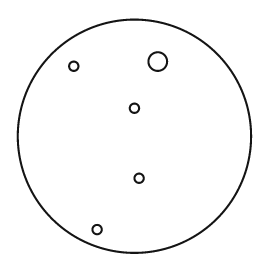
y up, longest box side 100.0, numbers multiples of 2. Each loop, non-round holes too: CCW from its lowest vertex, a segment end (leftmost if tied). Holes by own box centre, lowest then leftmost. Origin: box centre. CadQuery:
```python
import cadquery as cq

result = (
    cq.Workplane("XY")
    .moveTo(0.0, 0.0)
    .circle(50.0)
    .moveTo(-16.0, -40.0)
    .circle(2.0)
    .moveTo(2.0, -18.0)
    .circle(2.0)
    .moveTo(0.0, 12.0)
    .circle(2.0)
    .moveTo(-26.0, 30.0)
    .circle(2.0)
    .moveTo(10.0, 32.0)
    .circle(4.0)
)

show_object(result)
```